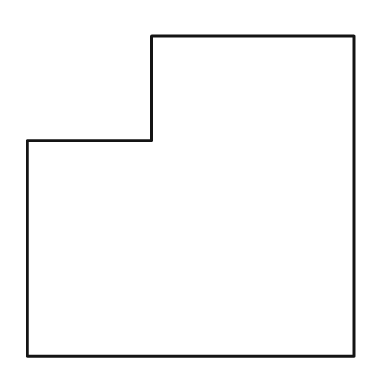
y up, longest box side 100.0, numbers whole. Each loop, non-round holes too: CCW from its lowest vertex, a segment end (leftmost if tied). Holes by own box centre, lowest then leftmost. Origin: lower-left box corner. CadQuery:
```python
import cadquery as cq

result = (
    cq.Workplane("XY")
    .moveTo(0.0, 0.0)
    .lineTo(100.0, 0.0)
    .lineTo(100.0, 98.0)
    .lineTo(38.0, 98.0)
    .lineTo(38.0, 66.0)
    .lineTo(0.0, 66.0)
    .close()
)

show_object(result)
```